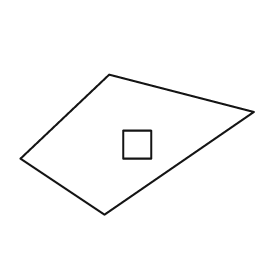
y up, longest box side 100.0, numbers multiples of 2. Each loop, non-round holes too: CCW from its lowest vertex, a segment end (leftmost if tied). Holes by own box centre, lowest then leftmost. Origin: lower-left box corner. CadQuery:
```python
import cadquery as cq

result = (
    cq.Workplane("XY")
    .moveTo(36.0, 0.0)
    .lineTo(100.0, 44.0)
    .lineTo(38.0, 60.0)
    .lineTo(0.0, 24.0)
    .close()
    .moveTo(44.0, 24.0)
    .lineTo(56.0, 24.0)
    .lineTo(56.0, 36.0)
    .lineTo(44.0, 36.0)
    .close()
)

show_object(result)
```